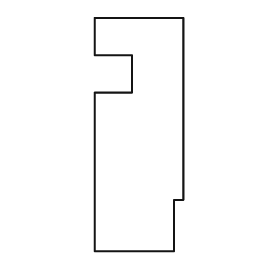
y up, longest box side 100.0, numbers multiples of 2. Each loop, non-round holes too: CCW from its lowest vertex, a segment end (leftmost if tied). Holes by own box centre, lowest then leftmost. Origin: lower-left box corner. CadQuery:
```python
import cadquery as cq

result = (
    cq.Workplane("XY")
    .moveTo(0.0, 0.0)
    .lineTo(34.0, 0.0)
    .lineTo(34.0, 22.0)
    .lineTo(38.0, 22.0)
    .lineTo(38.0, 100.0)
    .lineTo(0.0, 100.0)
    .lineTo(0.0, 84.0)
    .lineTo(16.0, 84.0)
    .lineTo(16.0, 68.0)
    .lineTo(0.0, 68.0)
    .close()
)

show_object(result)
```